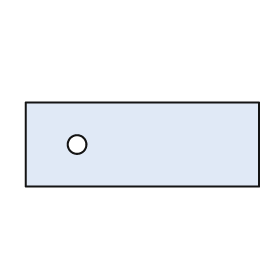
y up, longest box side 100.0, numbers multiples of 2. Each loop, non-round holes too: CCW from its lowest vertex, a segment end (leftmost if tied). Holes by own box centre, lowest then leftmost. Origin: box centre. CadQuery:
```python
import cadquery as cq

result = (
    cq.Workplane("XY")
    .moveTo(-50.0, -18.0)
    .lineTo(50.0, -18.0)
    .lineTo(50.0, 18.0)
    .lineTo(-50.0, 18.0)
    .close()
    .moveTo(-28.0, 0.0)
    .circle(4.0)
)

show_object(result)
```